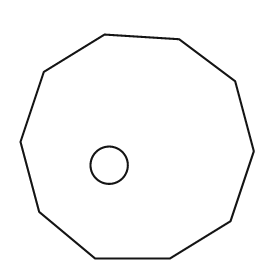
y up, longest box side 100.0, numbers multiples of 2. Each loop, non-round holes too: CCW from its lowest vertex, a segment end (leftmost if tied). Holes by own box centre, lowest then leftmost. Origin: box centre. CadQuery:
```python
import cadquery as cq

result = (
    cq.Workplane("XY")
    .moveTo(-18.0, -48.0)
    .lineTo(14.0, -48.0)
    .lineTo(40.0, -32.0)
    .lineTo(50.0, -2.0)
    .lineTo(42.0, 28.0)
    .lineTo(18.0, 46.0)
    .lineTo(-14.0, 48.0)
    .lineTo(-40.0, 32.0)
    .lineTo(-50.0, 2.0)
    .lineTo(-42.0, -28.0)
    .close()
    .moveTo(-12.0, -8.0)
    .circle(8.0)
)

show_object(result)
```